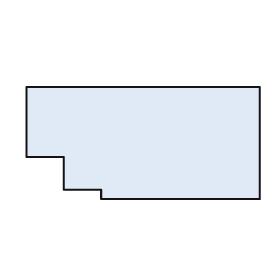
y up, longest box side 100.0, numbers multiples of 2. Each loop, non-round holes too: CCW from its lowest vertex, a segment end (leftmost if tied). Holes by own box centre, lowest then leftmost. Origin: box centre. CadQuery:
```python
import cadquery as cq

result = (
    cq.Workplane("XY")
    .moveTo(-18.0, -24.0)
    .lineTo(50.0, -24.0)
    .lineTo(50.0, 24.0)
    .lineTo(-50.0, 24.0)
    .lineTo(-50.0, -6.0)
    .lineTo(-34.0, -6.0)
    .lineTo(-34.0, -20.0)
    .lineTo(-18.0, -20.0)
    .close()
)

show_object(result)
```